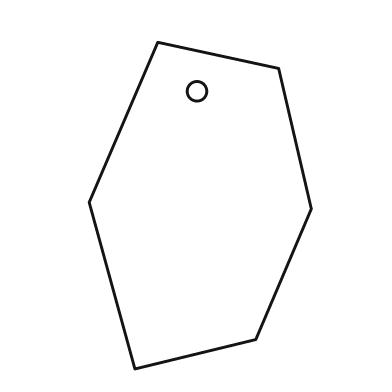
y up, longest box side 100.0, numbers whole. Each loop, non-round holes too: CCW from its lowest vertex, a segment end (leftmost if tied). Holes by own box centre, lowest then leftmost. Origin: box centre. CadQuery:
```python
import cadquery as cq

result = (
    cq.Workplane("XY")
    .moveTo(-20.0, -50.0)
    .lineTo(17.0, -41.0)
    .lineTo(34.0, -1.0)
    .lineTo(24.0, 42.0)
    .lineTo(-13.0, 50.0)
    .lineTo(-34.0, 1.0)
    .close()
    .moveTo(-1.0, 35.0)
    .circle(3.0)
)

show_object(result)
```